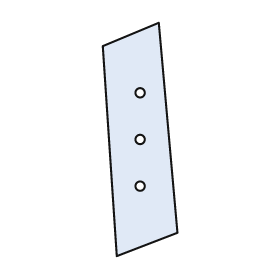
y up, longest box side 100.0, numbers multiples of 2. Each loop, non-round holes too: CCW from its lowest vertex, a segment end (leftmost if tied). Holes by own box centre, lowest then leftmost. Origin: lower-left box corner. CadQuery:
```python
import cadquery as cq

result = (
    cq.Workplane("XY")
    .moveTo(6.0, 0.0)
    .lineTo(32.0, 10.0)
    .lineTo(24.0, 100.0)
    .lineTo(0.0, 90.0)
    .close()
    .moveTo(16.0, 30.0)
    .circle(2.0)
    .moveTo(16.0, 50.0)
    .circle(2.0)
    .moveTo(16.0, 70.0)
    .circle(2.0)
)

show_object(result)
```